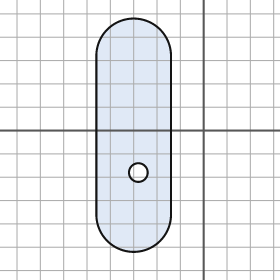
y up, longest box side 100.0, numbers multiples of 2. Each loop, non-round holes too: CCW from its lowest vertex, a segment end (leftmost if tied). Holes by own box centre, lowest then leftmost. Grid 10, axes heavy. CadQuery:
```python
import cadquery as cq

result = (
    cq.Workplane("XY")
    .moveTo(-46.0, -36.0)
    .threePointArc((-30.0, -52.0), (-14.0, -36.0))
    .lineTo(-14.0, 32.0)
    .threePointArc((-30.0, 48.0), (-46.0, 32.0))
    .close()
    .moveTo(-28.0, -18.0)
    .circle(4.0)
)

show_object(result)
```